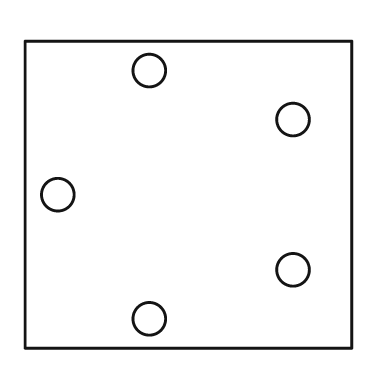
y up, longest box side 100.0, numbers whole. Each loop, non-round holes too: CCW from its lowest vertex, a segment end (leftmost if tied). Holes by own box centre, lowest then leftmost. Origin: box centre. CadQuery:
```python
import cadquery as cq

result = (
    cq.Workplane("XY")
    .moveTo(-50.0, -47.0)
    .lineTo(50.0, -47.0)
    .lineTo(50.0, 47.0)
    .lineTo(-50.0, 47.0)
    .close()
    .moveTo(-12.0, -38.0)
    .circle(5.0)
    .moveTo(32.0, -23.0)
    .circle(5.0)
    .moveTo(-40.0, 0.0)
    .circle(5.0)
    .moveTo(32.0, 23.0)
    .circle(5.0)
    .moveTo(-12.0, 38.0)
    .circle(5.0)
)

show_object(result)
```